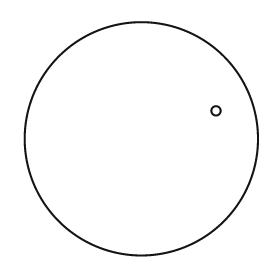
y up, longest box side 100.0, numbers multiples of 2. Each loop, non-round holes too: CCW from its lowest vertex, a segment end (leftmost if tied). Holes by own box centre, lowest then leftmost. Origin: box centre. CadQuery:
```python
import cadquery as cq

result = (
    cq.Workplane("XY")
    .moveTo(0.0, 0.0)
    .circle(50.0)
    .moveTo(32.0, 12.0)
    .circle(2.0)
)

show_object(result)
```